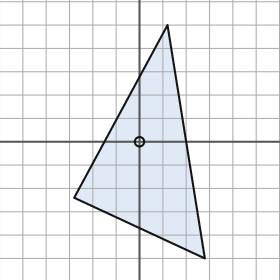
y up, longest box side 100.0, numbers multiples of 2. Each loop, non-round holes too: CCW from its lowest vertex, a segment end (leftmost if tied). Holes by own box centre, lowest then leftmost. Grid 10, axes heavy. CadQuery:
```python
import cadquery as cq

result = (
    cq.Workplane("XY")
    .moveTo(28.0, -50.0)
    .lineTo(12.0, 50.0)
    .lineTo(-28.0, -24.0)
    .close()
    .moveTo(0.0, 0.0)
    .circle(2.0)
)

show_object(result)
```